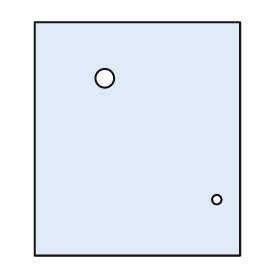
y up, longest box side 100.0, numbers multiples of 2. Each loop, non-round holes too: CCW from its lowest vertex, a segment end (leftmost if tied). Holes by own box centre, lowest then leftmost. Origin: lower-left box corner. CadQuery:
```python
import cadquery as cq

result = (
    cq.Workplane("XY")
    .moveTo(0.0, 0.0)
    .lineTo(88.0, 0.0)
    .lineTo(88.0, 100.0)
    .lineTo(0.0, 100.0)
    .close()
    .moveTo(78.0, 24.0)
    .circle(2.0)
    .moveTo(30.0, 76.0)
    .circle(4.0)
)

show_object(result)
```